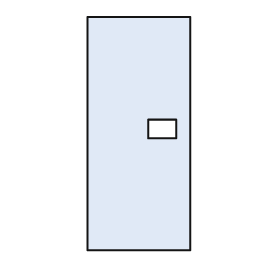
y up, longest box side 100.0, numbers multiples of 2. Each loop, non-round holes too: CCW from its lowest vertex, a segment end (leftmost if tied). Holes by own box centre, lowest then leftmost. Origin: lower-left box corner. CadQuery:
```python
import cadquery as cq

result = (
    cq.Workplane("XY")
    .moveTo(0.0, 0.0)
    .lineTo(44.0, 0.0)
    .lineTo(44.0, 100.0)
    .lineTo(0.0, 100.0)
    .close()
    .moveTo(26.0, 48.0)
    .lineTo(38.0, 48.0)
    .lineTo(38.0, 56.0)
    .lineTo(26.0, 56.0)
    .close()
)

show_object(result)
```